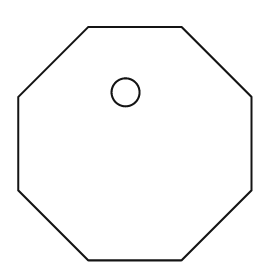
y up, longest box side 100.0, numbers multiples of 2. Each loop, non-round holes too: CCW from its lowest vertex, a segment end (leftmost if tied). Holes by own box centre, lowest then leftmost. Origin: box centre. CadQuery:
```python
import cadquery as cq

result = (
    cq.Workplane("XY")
    .moveTo(-20.0, -50.0)
    .lineTo(20.0, -50.0)
    .lineTo(50.0, -20.0)
    .lineTo(50.0, 20.0)
    .lineTo(20.0, 50.0)
    .lineTo(-20.0, 50.0)
    .lineTo(-50.0, 20.0)
    .lineTo(-50.0, -20.0)
    .close()
    .moveTo(-4.0, 22.0)
    .circle(6.0)
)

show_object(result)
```